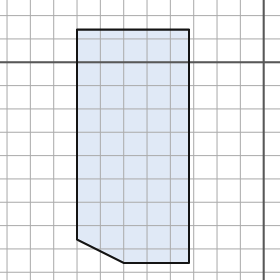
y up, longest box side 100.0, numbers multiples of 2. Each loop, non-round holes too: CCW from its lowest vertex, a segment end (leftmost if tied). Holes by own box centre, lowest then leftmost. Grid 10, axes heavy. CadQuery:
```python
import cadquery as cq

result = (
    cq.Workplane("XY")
    .moveTo(-60.0, -86.0)
    .lineTo(-32.0, -86.0)
    .lineTo(-32.0, 14.0)
    .lineTo(-80.0, 14.0)
    .lineTo(-80.0, -76.0)
    .close()
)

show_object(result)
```